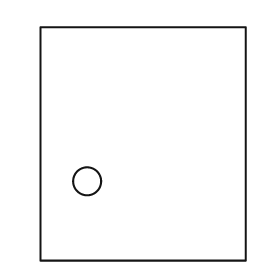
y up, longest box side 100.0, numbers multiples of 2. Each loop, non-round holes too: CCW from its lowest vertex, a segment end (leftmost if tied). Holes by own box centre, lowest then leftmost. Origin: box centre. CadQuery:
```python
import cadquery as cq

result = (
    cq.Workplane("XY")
    .moveTo(-44.0, -50.0)
    .lineTo(44.0, -50.0)
    .lineTo(44.0, 50.0)
    .lineTo(-44.0, 50.0)
    .close()
    .moveTo(-24.0, -16.0)
    .circle(6.0)
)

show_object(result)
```